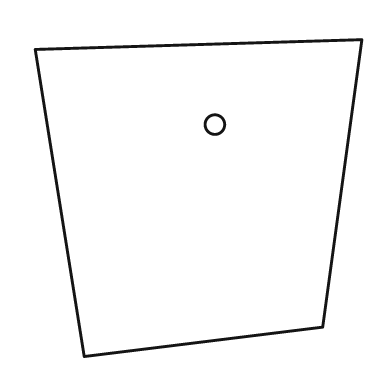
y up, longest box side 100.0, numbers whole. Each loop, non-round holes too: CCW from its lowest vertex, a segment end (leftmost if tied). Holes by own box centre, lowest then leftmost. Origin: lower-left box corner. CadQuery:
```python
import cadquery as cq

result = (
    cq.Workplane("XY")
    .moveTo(15.0, 0.0)
    .lineTo(88.0, 9.0)
    .lineTo(100.0, 97.0)
    .lineTo(0.0, 94.0)
    .close()
    .moveTo(55.0, 71.0)
    .circle(3.0)
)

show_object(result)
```